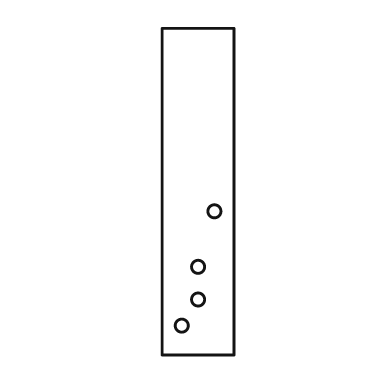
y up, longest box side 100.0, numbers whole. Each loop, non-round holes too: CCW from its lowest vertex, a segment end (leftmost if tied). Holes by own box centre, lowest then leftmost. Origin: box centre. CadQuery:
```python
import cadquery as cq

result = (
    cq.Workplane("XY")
    .moveTo(-11.0, -50.0)
    .lineTo(11.0, -50.0)
    .lineTo(11.0, 50.0)
    .lineTo(-11.0, 50.0)
    .close()
    .moveTo(-5.0, -41.0)
    .circle(2.0)
    .moveTo(0.0, -33.0)
    .circle(2.0)
    .moveTo(0.0, -23.0)
    .circle(2.0)
    .moveTo(5.0, -6.0)
    .circle(2.0)
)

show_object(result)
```